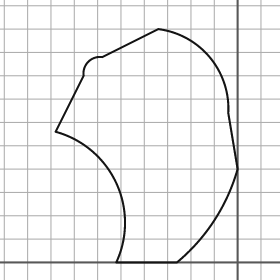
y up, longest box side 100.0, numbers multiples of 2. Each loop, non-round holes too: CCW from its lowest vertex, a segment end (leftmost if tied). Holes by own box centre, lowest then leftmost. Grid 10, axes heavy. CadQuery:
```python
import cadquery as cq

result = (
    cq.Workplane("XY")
    .moveTo(-52.0, 0.0)
    .lineTo(-26.0, 0.0)
    .threePointArc((-10.0, 18.0), (0.0, 40.0))
    .lineTo(-4.0, 64.0)
    .threePointArc((-12.0, 88.0), (-34.0, 100.0))
    .lineTo(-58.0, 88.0)
    .threePointArc((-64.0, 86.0), (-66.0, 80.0))
    .lineTo(-78.0, 56.0)
    .threePointArc((-52.0, 34.0), (-52.0, 0.0))
    .close()
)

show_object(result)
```